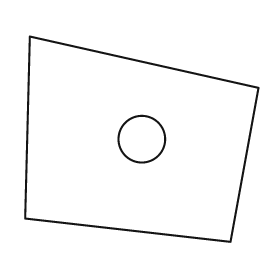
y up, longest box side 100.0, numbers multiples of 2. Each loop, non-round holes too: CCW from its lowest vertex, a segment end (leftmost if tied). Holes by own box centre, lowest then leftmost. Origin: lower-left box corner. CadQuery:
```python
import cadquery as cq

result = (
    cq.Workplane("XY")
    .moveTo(88.0, 0.0)
    .lineTo(100.0, 66.0)
    .lineTo(2.0, 88.0)
    .lineTo(0.0, 10.0)
    .close()
    .moveTo(50.0, 44.0)
    .circle(10.0)
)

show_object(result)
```